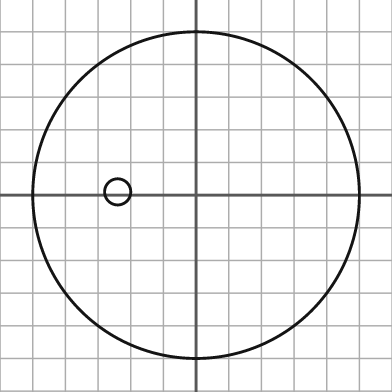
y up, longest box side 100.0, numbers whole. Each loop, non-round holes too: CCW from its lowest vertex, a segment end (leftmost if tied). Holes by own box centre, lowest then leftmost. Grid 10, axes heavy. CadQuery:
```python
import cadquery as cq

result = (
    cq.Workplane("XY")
    .moveTo(0.0, 0.0)
    .circle(50.0)
    .moveTo(-24.0, 1.0)
    .circle(4.0)
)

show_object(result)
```